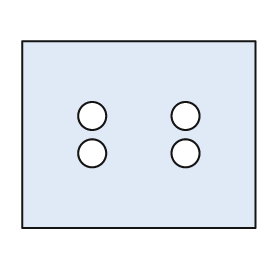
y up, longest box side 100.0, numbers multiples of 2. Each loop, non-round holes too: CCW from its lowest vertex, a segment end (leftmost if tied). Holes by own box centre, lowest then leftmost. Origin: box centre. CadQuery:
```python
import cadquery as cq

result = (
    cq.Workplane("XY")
    .moveTo(-50.0, -40.0)
    .lineTo(50.0, -40.0)
    .lineTo(50.0, 40.0)
    .lineTo(-50.0, 40.0)
    .close()
    .moveTo(-20.0, -8.0)
    .circle(6.0)
    .moveTo(20.0, -8.0)
    .circle(6.0)
    .moveTo(-20.0, 8.0)
    .circle(6.0)
    .moveTo(20.0, 8.0)
    .circle(6.0)
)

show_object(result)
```